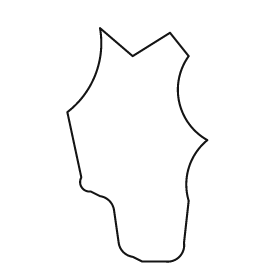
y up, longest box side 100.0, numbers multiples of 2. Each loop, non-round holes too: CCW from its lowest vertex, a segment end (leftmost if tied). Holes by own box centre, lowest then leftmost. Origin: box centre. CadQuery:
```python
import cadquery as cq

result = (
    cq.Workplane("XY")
    .moveTo(2.0, -50.0)
    .lineTo(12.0, -50.0)
    .threePointArc((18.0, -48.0), (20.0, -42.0))
    .lineTo(22.0, -24.0)
    .threePointArc((22.0, -10.0), (30.0, 2.0))
    .threePointArc((18.0, 18.0), (22.0, 38.0))
    .lineTo(14.0, 48.0)
    .lineTo(-2.0, 38.0)
    .lineTo(-16.0, 50.0)
    .threePointArc((-18.0, 30.0), (-30.0, 14.0))
    .lineTo(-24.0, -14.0)
    .threePointArc((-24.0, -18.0), (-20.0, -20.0))
    .lineTo(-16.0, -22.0)
    .threePointArc((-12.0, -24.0), (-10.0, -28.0))
    .lineTo(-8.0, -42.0)
    .threePointArc((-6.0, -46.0), (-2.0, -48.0))
    .close()
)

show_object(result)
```